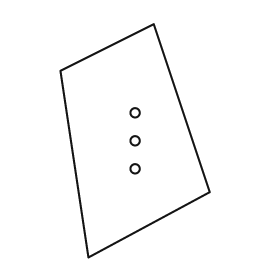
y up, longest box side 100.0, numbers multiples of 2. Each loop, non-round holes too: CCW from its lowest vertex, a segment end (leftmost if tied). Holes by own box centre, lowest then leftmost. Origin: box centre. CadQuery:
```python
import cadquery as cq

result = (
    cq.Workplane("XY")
    .moveTo(-20.0, -50.0)
    .lineTo(32.0, -22.0)
    .lineTo(8.0, 50.0)
    .lineTo(-32.0, 30.0)
    .close()
    .moveTo(0.0, -12.0)
    .circle(2.0)
    .moveTo(0.0, 0.0)
    .circle(2.0)
    .moveTo(0.0, 12.0)
    .circle(2.0)
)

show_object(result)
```